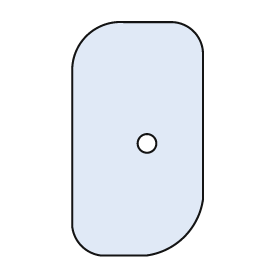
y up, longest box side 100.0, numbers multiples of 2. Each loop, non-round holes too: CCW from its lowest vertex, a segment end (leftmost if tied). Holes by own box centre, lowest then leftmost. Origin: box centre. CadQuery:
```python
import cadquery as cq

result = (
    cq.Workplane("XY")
    .moveTo(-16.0, -50.0)
    .lineTo(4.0, -50.0)
    .threePointArc((20.0, -42.0), (28.0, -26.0))
    .lineTo(28.0, 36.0)
    .threePointArc((24.0, 46.0), (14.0, 50.0))
    .lineTo(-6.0, 50.0)
    .threePointArc((-22.0, 44.0), (-28.0, 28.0))
    .lineTo(-28.0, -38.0)
    .threePointArc((-24.0, -46.0), (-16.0, -50.0))
    .close()
    .moveTo(4.0, -2.0)
    .circle(4.0)
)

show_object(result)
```